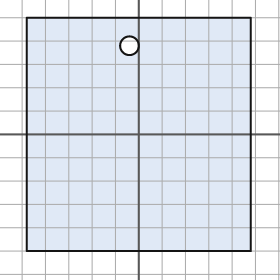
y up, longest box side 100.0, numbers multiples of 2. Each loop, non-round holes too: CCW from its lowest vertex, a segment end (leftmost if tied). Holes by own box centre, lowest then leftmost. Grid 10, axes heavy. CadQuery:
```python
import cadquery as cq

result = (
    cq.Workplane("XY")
    .moveTo(-48.0, -50.0)
    .lineTo(48.0, -50.0)
    .lineTo(48.0, 50.0)
    .lineTo(-48.0, 50.0)
    .close()
    .moveTo(-4.0, 38.0)
    .circle(4.0)
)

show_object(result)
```